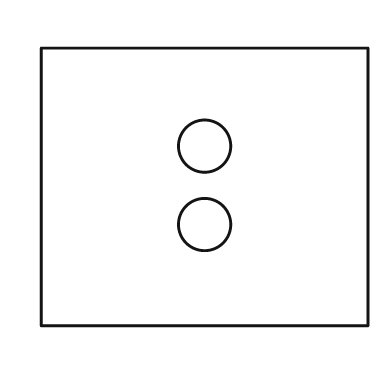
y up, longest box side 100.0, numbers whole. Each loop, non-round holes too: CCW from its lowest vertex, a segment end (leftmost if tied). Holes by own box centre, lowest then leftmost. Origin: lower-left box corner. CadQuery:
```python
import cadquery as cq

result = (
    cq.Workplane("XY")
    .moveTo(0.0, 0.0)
    .lineTo(100.0, 0.0)
    .lineTo(100.0, 85.0)
    .lineTo(0.0, 85.0)
    .close()
    .moveTo(50.0, 31.0)
    .circle(8.0)
    .moveTo(50.0, 55.0)
    .circle(8.0)
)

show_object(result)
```